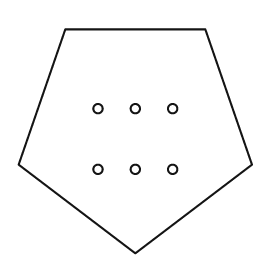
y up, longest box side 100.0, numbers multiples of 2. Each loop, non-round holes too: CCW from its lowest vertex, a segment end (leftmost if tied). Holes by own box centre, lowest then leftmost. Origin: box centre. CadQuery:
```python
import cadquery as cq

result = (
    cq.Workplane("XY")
    .moveTo(0.0, -48.0)
    .lineTo(50.0, -10.0)
    .lineTo(30.0, 48.0)
    .lineTo(-30.0, 48.0)
    .lineTo(-50.0, -10.0)
    .close()
    .moveTo(-16.0, -12.0)
    .circle(2.0)
    .moveTo(0.0, -12.0)
    .circle(2.0)
    .moveTo(16.0, -12.0)
    .circle(2.0)
    .moveTo(-16.0, 14.0)
    .circle(2.0)
    .moveTo(0.0, 14.0)
    .circle(2.0)
    .moveTo(16.0, 14.0)
    .circle(2.0)
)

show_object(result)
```